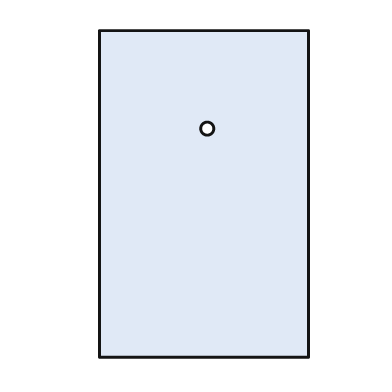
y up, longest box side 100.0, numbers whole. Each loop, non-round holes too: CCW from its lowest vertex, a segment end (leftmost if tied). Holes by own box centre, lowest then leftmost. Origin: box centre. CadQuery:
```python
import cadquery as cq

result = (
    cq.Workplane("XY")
    .moveTo(-32.0, -50.0)
    .lineTo(32.0, -50.0)
    .lineTo(32.0, 50.0)
    .lineTo(-32.0, 50.0)
    .close()
    .moveTo(1.0, 20.0)
    .circle(2.0)
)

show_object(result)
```